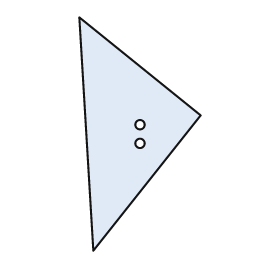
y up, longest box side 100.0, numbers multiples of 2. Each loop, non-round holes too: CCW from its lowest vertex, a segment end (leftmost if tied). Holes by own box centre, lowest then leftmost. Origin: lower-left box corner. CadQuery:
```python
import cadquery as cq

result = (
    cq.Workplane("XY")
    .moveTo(6.0, 0.0)
    .lineTo(52.0, 58.0)
    .lineTo(0.0, 100.0)
    .close()
    .moveTo(26.0, 46.0)
    .circle(2.0)
    .moveTo(26.0, 54.0)
    .circle(2.0)
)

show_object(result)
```